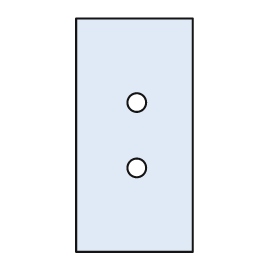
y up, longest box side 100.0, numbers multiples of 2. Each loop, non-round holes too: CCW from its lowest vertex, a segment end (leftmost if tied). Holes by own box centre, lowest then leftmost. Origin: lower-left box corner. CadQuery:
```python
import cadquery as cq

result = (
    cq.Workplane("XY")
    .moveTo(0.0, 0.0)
    .lineTo(50.0, 0.0)
    .lineTo(50.0, 100.0)
    .lineTo(0.0, 100.0)
    .close()
    .moveTo(26.0, 36.0)
    .circle(4.0)
    .moveTo(26.0, 64.0)
    .circle(4.0)
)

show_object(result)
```